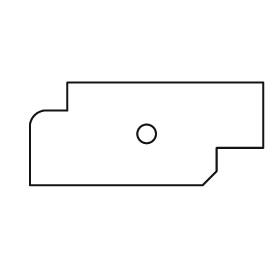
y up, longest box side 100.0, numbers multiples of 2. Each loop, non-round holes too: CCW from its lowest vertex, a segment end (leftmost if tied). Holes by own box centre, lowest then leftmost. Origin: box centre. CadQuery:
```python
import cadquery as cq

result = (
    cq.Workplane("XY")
    .moveTo(-50.0, -22.0)
    .lineTo(24.0, -22.0)
    .lineTo(30.0, -16.0)
    .lineTo(30.0, -6.0)
    .lineTo(50.0, -6.0)
    .lineTo(50.0, 22.0)
    .lineTo(-34.0, 22.0)
    .lineTo(-34.0, 10.0)
    .lineTo(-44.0, 10.0)
    .threePointArc((-48.0, 8.0), (-50.0, 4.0))
    .close()
    .moveTo(0.0, 0.0)
    .circle(4.0)
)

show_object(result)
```